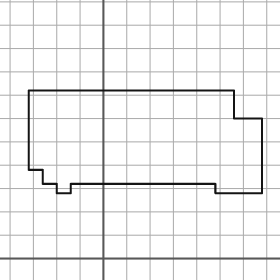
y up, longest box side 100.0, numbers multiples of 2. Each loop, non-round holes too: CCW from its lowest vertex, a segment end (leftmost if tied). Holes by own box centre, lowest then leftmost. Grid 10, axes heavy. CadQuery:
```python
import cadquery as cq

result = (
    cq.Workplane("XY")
    .moveTo(-20.0, 28.0)
    .lineTo(-14.0, 28.0)
    .lineTo(-14.0, 32.0)
    .lineTo(48.0, 32.0)
    .lineTo(48.0, 28.0)
    .lineTo(68.0, 28.0)
    .lineTo(68.0, 60.0)
    .lineTo(56.0, 60.0)
    .lineTo(56.0, 72.0)
    .lineTo(-32.0, 72.0)
    .lineTo(-32.0, 38.0)
    .lineTo(-26.0, 38.0)
    .lineTo(-26.0, 32.0)
    .lineTo(-20.0, 32.0)
    .close()
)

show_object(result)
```